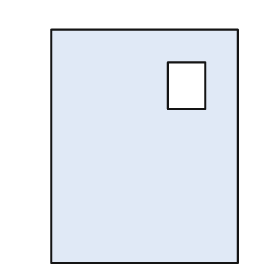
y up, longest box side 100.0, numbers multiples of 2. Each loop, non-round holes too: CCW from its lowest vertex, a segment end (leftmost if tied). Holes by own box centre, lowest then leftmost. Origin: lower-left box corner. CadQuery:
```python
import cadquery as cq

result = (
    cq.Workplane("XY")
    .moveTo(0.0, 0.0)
    .lineTo(80.0, 0.0)
    .lineTo(80.0, 100.0)
    .lineTo(0.0, 100.0)
    .close()
    .moveTo(50.0, 66.0)
    .lineTo(66.0, 66.0)
    .lineTo(66.0, 86.0)
    .lineTo(50.0, 86.0)
    .close()
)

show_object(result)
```